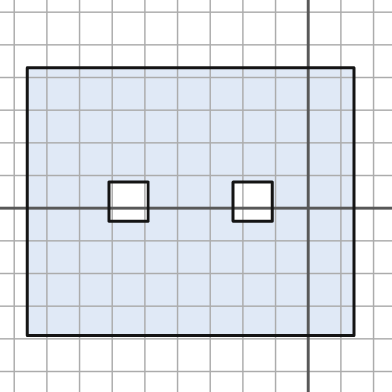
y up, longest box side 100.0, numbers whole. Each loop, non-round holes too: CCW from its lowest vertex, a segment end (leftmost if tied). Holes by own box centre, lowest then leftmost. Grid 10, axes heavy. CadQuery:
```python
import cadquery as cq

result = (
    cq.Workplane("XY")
    .moveTo(-86.0, -39.0)
    .lineTo(14.0, -39.0)
    .lineTo(14.0, 43.0)
    .lineTo(-86.0, 43.0)
    .close()
    .moveTo(-61.0, -4.0)
    .lineTo(-49.0, -4.0)
    .lineTo(-49.0, 8.0)
    .lineTo(-61.0, 8.0)
    .close()
    .moveTo(-23.0, -4.0)
    .lineTo(-11.0, -4.0)
    .lineTo(-11.0, 8.0)
    .lineTo(-23.0, 8.0)
    .close()
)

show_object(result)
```